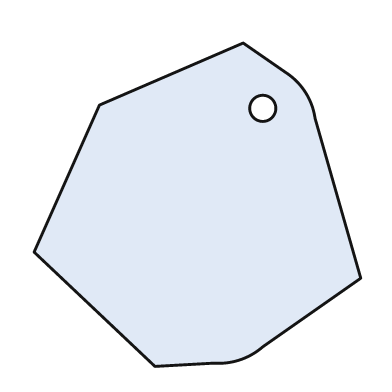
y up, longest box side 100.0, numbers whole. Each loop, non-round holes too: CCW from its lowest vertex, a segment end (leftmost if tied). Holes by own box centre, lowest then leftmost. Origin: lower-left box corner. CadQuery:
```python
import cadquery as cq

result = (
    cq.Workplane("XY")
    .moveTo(37.0, 0.0)
    .lineTo(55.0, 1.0)
    .threePointArc((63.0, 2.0), (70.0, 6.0))
    .lineTo(100.0, 27.0)
    .lineTo(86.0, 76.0)
    .threePointArc((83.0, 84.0), (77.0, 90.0))
    .lineTo(64.0, 99.0)
    .lineTo(20.0, 80.0)
    .lineTo(0.0, 35.0)
    .close()
    .moveTo(70.0, 79.0)
    .circle(4.0)
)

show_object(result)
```